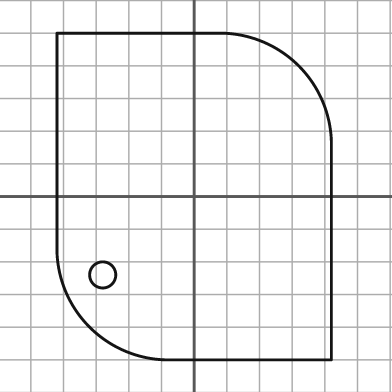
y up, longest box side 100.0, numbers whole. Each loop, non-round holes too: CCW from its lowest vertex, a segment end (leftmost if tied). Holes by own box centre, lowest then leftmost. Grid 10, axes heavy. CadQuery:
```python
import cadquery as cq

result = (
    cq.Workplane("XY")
    .moveTo(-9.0, -50.0)
    .lineTo(42.0, -50.0)
    .lineTo(42.0, 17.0)
    .threePointArc((32.0, 40.0), (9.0, 50.0))
    .lineTo(-42.0, 50.0)
    .lineTo(-42.0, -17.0)
    .threePointArc((-32.0, -40.0), (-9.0, -50.0))
    .close()
    .moveTo(-28.0, -24.0)
    .circle(4.0)
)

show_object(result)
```